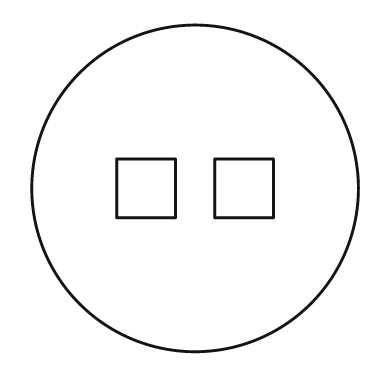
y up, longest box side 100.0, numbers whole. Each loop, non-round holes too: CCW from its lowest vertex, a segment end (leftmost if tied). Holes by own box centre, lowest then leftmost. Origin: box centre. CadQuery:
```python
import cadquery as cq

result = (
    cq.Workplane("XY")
    .moveTo(0.0, 0.0)
    .circle(50.0)
    .moveTo(-24.0, -9.0)
    .lineTo(-6.0, -9.0)
    .lineTo(-6.0, 9.0)
    .lineTo(-24.0, 9.0)
    .close()
    .moveTo(6.0, -9.0)
    .lineTo(24.0, -9.0)
    .lineTo(24.0, 9.0)
    .lineTo(6.0, 9.0)
    .close()
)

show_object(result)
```